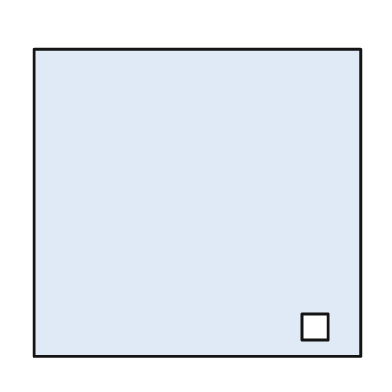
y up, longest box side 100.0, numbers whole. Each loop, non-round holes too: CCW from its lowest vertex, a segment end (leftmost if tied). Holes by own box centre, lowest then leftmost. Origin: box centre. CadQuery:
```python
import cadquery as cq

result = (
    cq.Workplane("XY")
    .moveTo(-50.0, -47.0)
    .lineTo(50.0, -47.0)
    .lineTo(50.0, 47.0)
    .lineTo(-50.0, 47.0)
    .close()
    .moveTo(32.0, -42.0)
    .lineTo(40.0, -42.0)
    .lineTo(40.0, -34.0)
    .lineTo(32.0, -34.0)
    .close()
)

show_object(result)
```